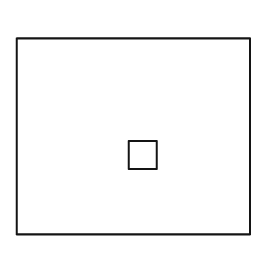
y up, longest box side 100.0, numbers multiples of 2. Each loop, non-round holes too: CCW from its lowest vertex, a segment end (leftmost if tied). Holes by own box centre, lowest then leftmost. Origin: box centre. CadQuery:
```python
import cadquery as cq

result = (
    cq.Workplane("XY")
    .moveTo(-50.0, -42.0)
    .lineTo(50.0, -42.0)
    .lineTo(50.0, 42.0)
    .lineTo(-50.0, 42.0)
    .close()
    .moveTo(-2.0, -14.0)
    .lineTo(10.0, -14.0)
    .lineTo(10.0, -2.0)
    .lineTo(-2.0, -2.0)
    .close()
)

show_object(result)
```